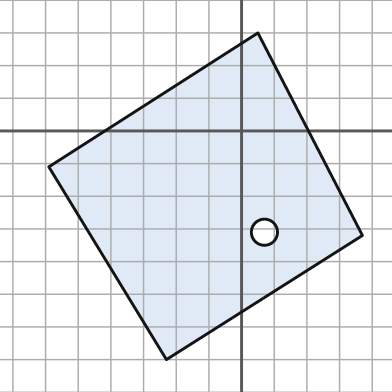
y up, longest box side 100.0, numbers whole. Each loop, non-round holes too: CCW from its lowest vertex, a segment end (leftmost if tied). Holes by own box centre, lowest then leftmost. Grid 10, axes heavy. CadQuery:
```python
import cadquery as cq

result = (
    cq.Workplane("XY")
    .moveTo(-23.0, -70.0)
    .lineTo(37.0, -32.0)
    .lineTo(5.0, 30.0)
    .lineTo(-59.0, -11.0)
    .close()
    .moveTo(7.0, -31.0)
    .circle(4.0)
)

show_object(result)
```